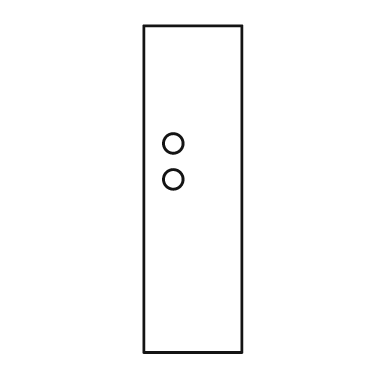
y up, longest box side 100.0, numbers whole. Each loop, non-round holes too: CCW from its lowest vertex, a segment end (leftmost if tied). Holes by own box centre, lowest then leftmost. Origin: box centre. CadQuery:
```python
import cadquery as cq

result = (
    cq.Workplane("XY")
    .moveTo(-15.0, -50.0)
    .lineTo(15.0, -50.0)
    .lineTo(15.0, 50.0)
    .lineTo(-15.0, 50.0)
    .close()
    .moveTo(-6.0, 3.0)
    .circle(3.0)
    .moveTo(-6.0, 14.0)
    .circle(3.0)
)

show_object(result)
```